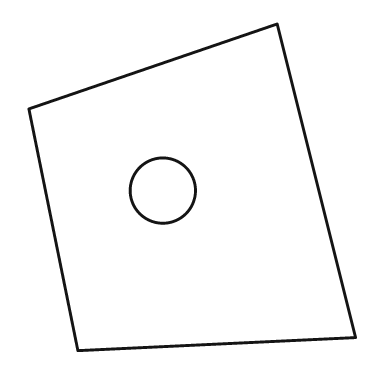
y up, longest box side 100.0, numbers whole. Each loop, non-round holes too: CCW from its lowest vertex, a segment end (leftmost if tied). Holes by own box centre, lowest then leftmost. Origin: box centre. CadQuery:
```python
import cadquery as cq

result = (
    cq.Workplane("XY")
    .moveTo(-35.0, -50.0)
    .lineTo(50.0, -46.0)
    .lineTo(26.0, 50.0)
    .lineTo(-50.0, 24.0)
    .close()
    .moveTo(-9.0, -1.0)
    .circle(10.0)
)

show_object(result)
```